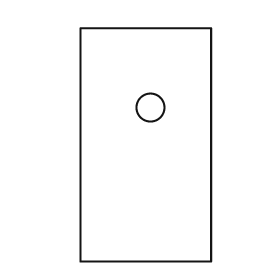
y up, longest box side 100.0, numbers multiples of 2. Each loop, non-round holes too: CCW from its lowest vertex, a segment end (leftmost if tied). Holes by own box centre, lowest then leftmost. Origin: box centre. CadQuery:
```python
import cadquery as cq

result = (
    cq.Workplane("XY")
    .moveTo(-28.0, -50.0)
    .lineTo(28.0, -50.0)
    .lineTo(28.0, 50.0)
    .lineTo(-28.0, 50.0)
    .close()
    .moveTo(2.0, 16.0)
    .circle(6.0)
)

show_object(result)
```